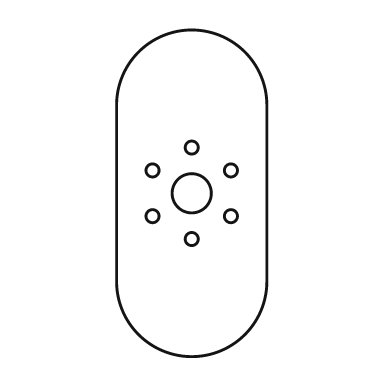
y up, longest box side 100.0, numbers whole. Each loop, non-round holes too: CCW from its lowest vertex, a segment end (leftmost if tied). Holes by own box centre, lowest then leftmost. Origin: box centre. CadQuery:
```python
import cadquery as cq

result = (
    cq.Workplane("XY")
    .moveTo(-23.0, -27.0)
    .threePointArc((0.0, -50.0), (23.0, -27.0))
    .lineTo(23.0, 27.0)
    .threePointArc((0.0, 50.0), (-23.0, 27.0))
    .close()
    .moveTo(0.0, -14.0)
    .circle(2.0)
    .moveTo(-12.0, -7.0)
    .circle(2.0)
    .moveTo(12.0, -7.0)
    .circle(2.0)
    .moveTo(0.0, 0.0)
    .circle(6.0)
    .moveTo(-12.0, 7.0)
    .circle(2.0)
    .moveTo(12.0, 7.0)
    .circle(2.0)
    .moveTo(0.0, 14.0)
    .circle(2.0)
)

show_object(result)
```